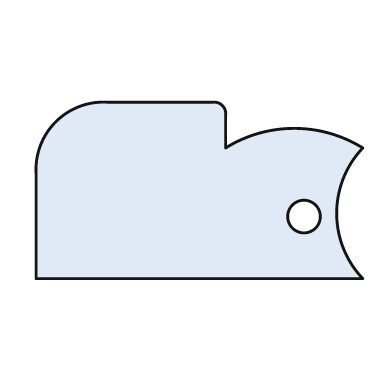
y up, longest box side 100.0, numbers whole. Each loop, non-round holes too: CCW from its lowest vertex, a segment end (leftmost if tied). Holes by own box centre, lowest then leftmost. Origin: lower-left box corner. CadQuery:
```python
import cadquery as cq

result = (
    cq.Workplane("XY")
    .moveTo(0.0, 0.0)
    .lineTo(100.0, 0.0)
    .threePointArc((92.0, 20.0), (100.0, 40.0))
    .threePointArc((79.0, 46.0), (58.0, 40.0))
    .lineTo(58.0, 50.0)
    .threePointArc((57.0, 53.0), (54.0, 54.0))
    .lineTo(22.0, 54.0)
    .threePointArc((6.0, 48.0), (0.0, 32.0))
    .close()
    .moveTo(82.0, 19.0)
    .circle(5.0)
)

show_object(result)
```